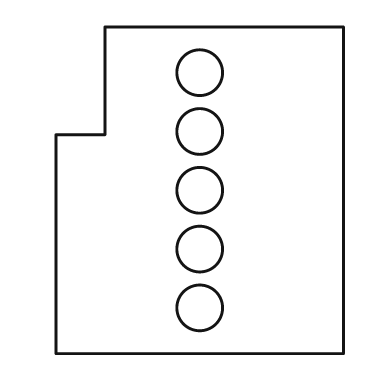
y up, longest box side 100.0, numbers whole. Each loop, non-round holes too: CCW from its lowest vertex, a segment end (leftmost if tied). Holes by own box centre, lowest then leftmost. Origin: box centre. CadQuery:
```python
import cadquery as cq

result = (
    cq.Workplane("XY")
    .moveTo(-44.0, -50.0)
    .lineTo(44.0, -50.0)
    .lineTo(44.0, 50.0)
    .lineTo(-29.0, 50.0)
    .lineTo(-29.0, 17.0)
    .lineTo(-44.0, 17.0)
    .close()
    .moveTo(0.0, -36.0)
    .circle(7.0)
    .moveTo(0.0, -18.0)
    .circle(7.0)
    .moveTo(0.0, 0.0)
    .circle(7.0)
    .moveTo(0.0, 18.0)
    .circle(7.0)
    .moveTo(0.0, 36.0)
    .circle(7.0)
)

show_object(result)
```